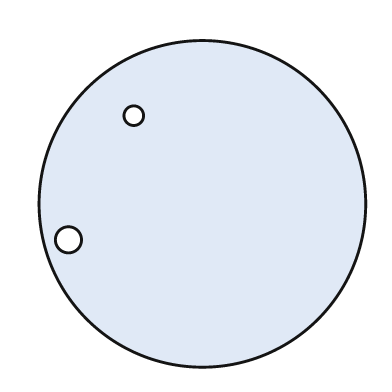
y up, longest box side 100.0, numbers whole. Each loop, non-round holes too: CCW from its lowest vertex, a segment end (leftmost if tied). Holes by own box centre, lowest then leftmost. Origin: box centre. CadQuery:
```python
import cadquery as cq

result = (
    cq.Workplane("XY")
    .moveTo(0.0, 0.0)
    .circle(50.0)
    .moveTo(-41.0, -11.0)
    .circle(4.0)
    .moveTo(-21.0, 27.0)
    .circle(3.0)
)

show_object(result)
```